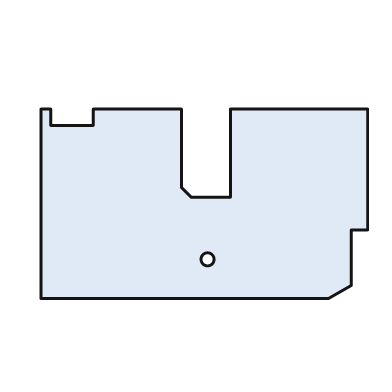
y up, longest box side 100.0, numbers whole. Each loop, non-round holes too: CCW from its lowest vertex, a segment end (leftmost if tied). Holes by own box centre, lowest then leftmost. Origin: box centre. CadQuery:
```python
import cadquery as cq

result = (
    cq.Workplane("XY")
    .moveTo(-50.0, -29.0)
    .lineTo(38.0, -29.0)
    .lineTo(45.0, -25.0)
    .lineTo(45.0, -8.0)
    .lineTo(50.0, -8.0)
    .lineTo(50.0, 29.0)
    .lineTo(8.0, 29.0)
    .lineTo(8.0, 2.0)
    .lineTo(-4.0, 2.0)
    .lineTo(-7.0, 5.0)
    .lineTo(-7.0, 29.0)
    .lineTo(-34.0, 29.0)
    .lineTo(-34.0, 24.0)
    .lineTo(-47.0, 24.0)
    .lineTo(-47.0, 29.0)
    .lineTo(-50.0, 29.0)
    .close()
    .moveTo(1.0, -17.0)
    .circle(2.0)
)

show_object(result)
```